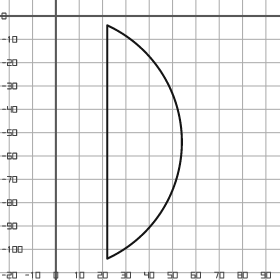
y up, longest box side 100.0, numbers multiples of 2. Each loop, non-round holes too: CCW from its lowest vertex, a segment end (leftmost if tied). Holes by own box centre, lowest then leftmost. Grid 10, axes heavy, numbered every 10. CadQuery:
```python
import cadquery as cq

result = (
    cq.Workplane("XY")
    .moveTo(22.0, -104.0)
    .threePointArc((54.0, -54.0), (22.0, -4.0))
    .close()
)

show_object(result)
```